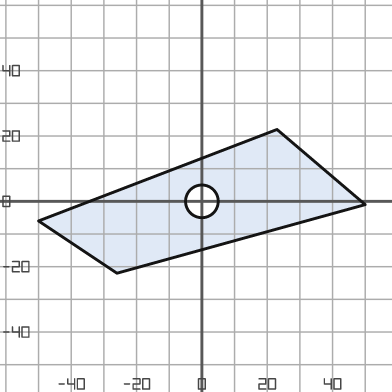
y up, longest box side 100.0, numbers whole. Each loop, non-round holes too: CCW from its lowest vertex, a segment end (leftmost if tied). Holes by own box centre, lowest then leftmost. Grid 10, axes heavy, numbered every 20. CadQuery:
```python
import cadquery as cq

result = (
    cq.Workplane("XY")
    .moveTo(-26.0, -22.0)
    .lineTo(50.0, -1.0)
    .lineTo(23.0, 22.0)
    .lineTo(-50.0, -6.0)
    .close()
    .moveTo(0.0, 0.0)
    .circle(5.0)
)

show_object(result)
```